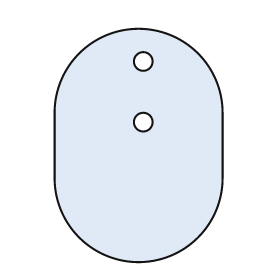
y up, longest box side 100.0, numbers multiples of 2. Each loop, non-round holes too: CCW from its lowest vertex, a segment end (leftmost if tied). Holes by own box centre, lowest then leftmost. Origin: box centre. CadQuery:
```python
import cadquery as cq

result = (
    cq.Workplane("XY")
    .moveTo(-36.0, -14.0)
    .threePointArc((0.0, -50.0), (36.0, -14.0))
    .lineTo(36.0, 14.0)
    .threePointArc((0.0, 50.0), (-36.0, 14.0))
    .close()
    .moveTo(2.0, 10.0)
    .circle(4.0)
    .moveTo(2.0, 36.0)
    .circle(4.0)
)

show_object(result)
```